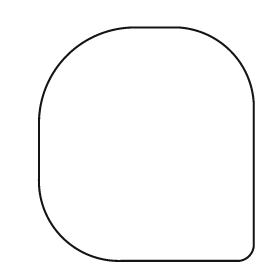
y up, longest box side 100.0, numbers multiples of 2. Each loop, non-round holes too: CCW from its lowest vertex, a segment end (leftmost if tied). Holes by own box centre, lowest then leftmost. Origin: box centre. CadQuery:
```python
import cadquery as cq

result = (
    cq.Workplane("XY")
    .moveTo(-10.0, -50.0)
    .lineTo(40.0, -50.0)
    .threePointArc((44.0, -48.0), (46.0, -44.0))
    .lineTo(46.0, 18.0)
    .threePointArc((36.0, 40.0), (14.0, 50.0))
    .lineTo(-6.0, 50.0)
    .threePointArc((-34.0, 38.0), (-46.0, 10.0))
    .lineTo(-46.0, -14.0)
    .threePointArc((-36.0, -40.0), (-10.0, -50.0))
    .close()
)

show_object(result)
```